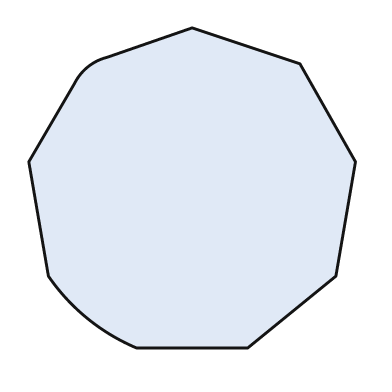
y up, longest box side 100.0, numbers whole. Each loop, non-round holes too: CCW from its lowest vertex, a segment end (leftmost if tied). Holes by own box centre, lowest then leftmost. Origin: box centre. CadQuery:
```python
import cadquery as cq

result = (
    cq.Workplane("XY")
    .moveTo(-17.0, -49.0)
    .lineTo(17.0, -49.0)
    .lineTo(44.0, -27.0)
    .lineTo(50.0, 8.0)
    .lineTo(33.0, 38.0)
    .lineTo(0.0, 49.0)
    .lineTo(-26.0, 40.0)
    .threePointArc((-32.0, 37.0), (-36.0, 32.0))
    .lineTo(-50.0, 8.0)
    .lineTo(-44.0, -27.0)
    .threePointArc((-32.0, -40.0), (-17.0, -49.0))
    .close()
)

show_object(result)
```